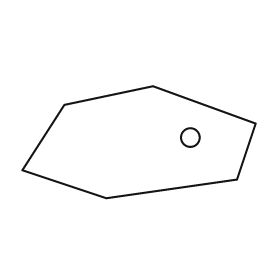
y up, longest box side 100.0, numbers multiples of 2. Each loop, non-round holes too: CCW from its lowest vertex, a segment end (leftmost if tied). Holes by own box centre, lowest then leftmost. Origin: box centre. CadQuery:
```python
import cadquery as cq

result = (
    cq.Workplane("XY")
    .moveTo(-14.0, -24.0)
    .lineTo(42.0, -16.0)
    .lineTo(50.0, 8.0)
    .lineTo(6.0, 24.0)
    .lineTo(-32.0, 16.0)
    .lineTo(-50.0, -12.0)
    .close()
    .moveTo(22.0, 2.0)
    .circle(4.0)
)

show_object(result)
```